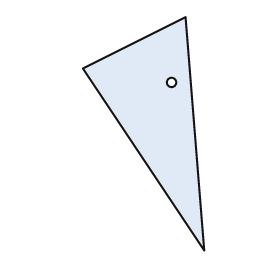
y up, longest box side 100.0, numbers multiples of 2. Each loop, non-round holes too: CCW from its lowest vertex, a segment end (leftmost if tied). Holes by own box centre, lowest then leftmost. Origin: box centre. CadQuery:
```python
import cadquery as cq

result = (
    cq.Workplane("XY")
    .moveTo(26.0, -50.0)
    .lineTo(18.0, 50.0)
    .lineTo(-26.0, 28.0)
    .close()
    .moveTo(12.0, 22.0)
    .circle(2.0)
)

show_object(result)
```